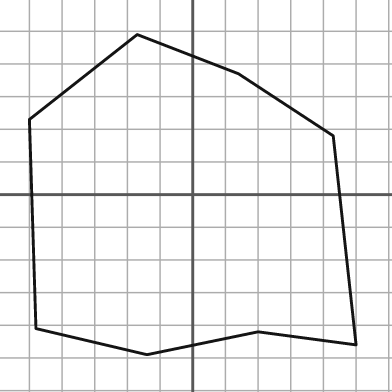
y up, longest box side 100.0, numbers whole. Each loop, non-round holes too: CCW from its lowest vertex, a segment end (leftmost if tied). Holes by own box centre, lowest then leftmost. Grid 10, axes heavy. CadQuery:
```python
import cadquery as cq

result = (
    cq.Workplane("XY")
    .moveTo(-14.0, -49.0)
    .lineTo(20.0, -42.0)
    .lineTo(50.0, -46.0)
    .lineTo(43.0, 18.0)
    .lineTo(14.0, 37.0)
    .lineTo(-17.0, 49.0)
    .lineTo(-50.0, 23.0)
    .lineTo(-48.0, -41.0)
    .close()
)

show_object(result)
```